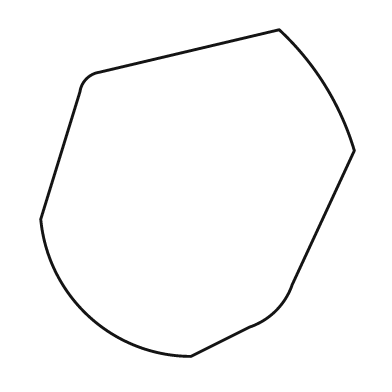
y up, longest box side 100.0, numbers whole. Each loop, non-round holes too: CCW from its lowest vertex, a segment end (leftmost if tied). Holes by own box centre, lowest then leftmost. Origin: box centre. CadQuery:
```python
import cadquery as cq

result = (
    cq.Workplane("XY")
    .moveTo(-2.0, -50.0)
    .lineTo(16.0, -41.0)
    .threePointArc((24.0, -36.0), (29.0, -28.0))
    .lineTo(48.0, 13.0)
    .threePointArc((39.0, 33.0), (25.0, 50.0))
    .lineTo(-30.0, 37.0)
    .threePointArc((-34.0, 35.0), (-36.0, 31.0))
    .lineTo(-48.0, -8.0)
    .threePointArc((-33.0, -38.0), (-2.0, -50.0))
    .close()
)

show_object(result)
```